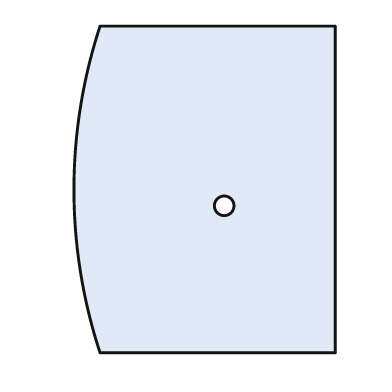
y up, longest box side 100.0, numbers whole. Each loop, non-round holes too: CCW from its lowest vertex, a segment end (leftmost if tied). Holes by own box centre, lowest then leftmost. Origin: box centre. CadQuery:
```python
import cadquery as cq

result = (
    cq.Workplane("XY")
    .moveTo(-32.0, -50.0)
    .lineTo(40.0, -50.0)
    .lineTo(40.0, 50.0)
    .lineTo(-32.0, 50.0)
    .threePointArc((-40.0, 0.0), (-32.0, -50.0))
    .close()
    .moveTo(6.0, -5.0)
    .circle(3.0)
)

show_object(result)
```